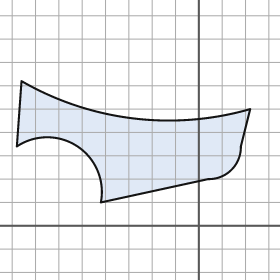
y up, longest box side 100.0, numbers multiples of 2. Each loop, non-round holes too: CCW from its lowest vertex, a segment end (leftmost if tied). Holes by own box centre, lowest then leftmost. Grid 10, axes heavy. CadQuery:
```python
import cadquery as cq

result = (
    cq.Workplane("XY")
    .moveTo(-42.0, 10.0)
    .lineTo(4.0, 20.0)
    .threePointArc((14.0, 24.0), (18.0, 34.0))
    .lineTo(22.0, 50.0)
    .threePointArc((-28.0, 46.0), (-76.0, 62.0))
    .lineTo(-78.0, 34.0)
    .threePointArc((-52.0, 34.0), (-42.0, 10.0))
    .close()
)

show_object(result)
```